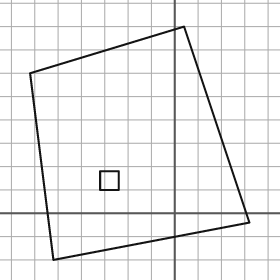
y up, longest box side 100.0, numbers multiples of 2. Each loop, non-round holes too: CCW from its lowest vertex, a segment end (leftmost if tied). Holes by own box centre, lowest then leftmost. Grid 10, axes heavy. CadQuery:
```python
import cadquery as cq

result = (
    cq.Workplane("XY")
    .moveTo(-52.0, -20.0)
    .lineTo(32.0, -4.0)
    .lineTo(4.0, 80.0)
    .lineTo(-62.0, 60.0)
    .close()
    .moveTo(-32.0, 10.0)
    .lineTo(-24.0, 10.0)
    .lineTo(-24.0, 18.0)
    .lineTo(-32.0, 18.0)
    .close()
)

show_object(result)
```